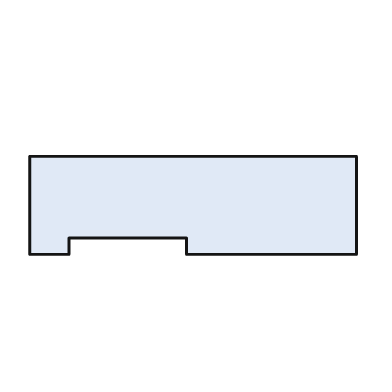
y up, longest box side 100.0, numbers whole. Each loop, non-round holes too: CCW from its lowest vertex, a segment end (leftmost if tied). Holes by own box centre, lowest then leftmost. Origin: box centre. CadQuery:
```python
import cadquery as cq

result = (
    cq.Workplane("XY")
    .moveTo(-50.0, -15.0)
    .lineTo(-38.0, -15.0)
    .lineTo(-38.0, -10.0)
    .lineTo(-2.0, -10.0)
    .lineTo(-2.0, -15.0)
    .lineTo(50.0, -15.0)
    .lineTo(50.0, 15.0)
    .lineTo(-50.0, 15.0)
    .close()
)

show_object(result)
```